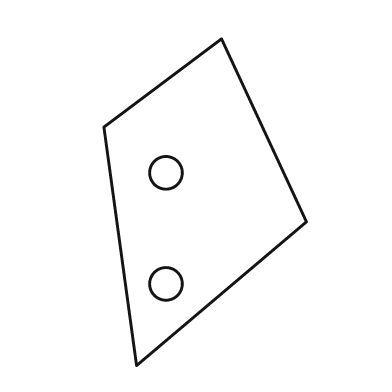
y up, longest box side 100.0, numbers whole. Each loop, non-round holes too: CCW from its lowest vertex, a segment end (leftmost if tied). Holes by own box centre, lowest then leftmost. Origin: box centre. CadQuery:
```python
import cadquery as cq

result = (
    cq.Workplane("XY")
    .moveTo(-21.0, -50.0)
    .lineTo(31.0, -6.0)
    .lineTo(5.0, 50.0)
    .lineTo(-31.0, 23.0)
    .close()
    .moveTo(-12.0, -25.0)
    .circle(5.0)
    .moveTo(-12.0, 9.0)
    .circle(5.0)
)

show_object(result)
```